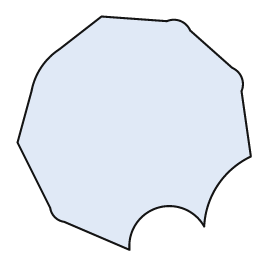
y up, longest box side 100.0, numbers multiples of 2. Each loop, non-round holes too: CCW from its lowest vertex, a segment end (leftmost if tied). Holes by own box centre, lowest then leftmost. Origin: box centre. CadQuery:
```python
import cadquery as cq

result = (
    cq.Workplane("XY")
    .moveTo(-2.0, -50.0)
    .threePointArc((10.0, -32.0), (30.0, -40.0))
    .threePointArc((36.0, -22.0), (50.0, -10.0))
    .lineTo(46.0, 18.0)
    .threePointArc((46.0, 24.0), (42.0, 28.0))
    .lineTo(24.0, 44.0)
    .threePointArc((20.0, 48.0), (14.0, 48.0))
    .lineTo(-14.0, 50.0)
    .lineTo(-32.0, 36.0)
    .threePointArc((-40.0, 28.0), (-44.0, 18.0))
    .lineTo(-50.0, -4.0)
    .lineTo(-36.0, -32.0)
    .threePointArc((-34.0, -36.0), (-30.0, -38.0))
    .close()
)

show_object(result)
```